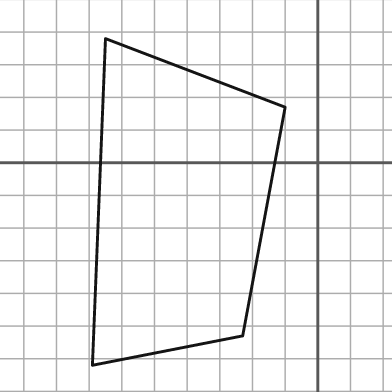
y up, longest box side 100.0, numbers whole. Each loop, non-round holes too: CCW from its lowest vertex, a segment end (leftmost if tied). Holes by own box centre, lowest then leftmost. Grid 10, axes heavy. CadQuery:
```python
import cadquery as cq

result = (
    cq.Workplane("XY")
    .moveTo(-69.0, -62.0)
    .lineTo(-23.0, -53.0)
    .lineTo(-10.0, 17.0)
    .lineTo(-65.0, 38.0)
    .close()
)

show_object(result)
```